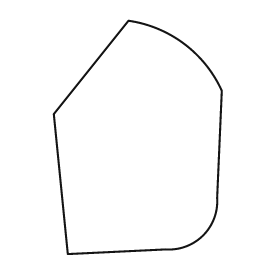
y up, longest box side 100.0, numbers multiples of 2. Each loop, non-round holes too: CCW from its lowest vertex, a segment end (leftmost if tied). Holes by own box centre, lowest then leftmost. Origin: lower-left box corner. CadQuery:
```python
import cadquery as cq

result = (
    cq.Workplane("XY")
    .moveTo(6.0, 0.0)
    .lineTo(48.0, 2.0)
    .threePointArc((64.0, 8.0), (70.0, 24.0))
    .lineTo(72.0, 70.0)
    .threePointArc((56.0, 90.0), (32.0, 100.0))
    .lineTo(0.0, 60.0)
    .close()
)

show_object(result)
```